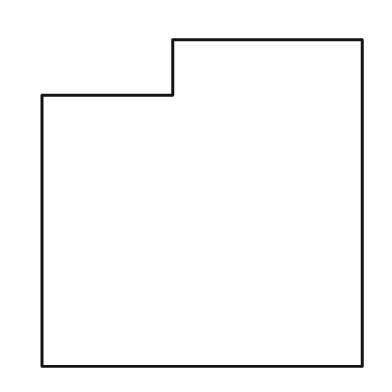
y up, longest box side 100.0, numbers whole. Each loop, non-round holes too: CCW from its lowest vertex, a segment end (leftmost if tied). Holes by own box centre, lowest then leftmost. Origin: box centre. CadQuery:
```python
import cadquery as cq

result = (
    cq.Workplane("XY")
    .moveTo(-49.0, -50.0)
    .lineTo(49.0, -50.0)
    .lineTo(49.0, 50.0)
    .lineTo(-9.0, 50.0)
    .lineTo(-9.0, 33.0)
    .lineTo(-49.0, 33.0)
    .close()
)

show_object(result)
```